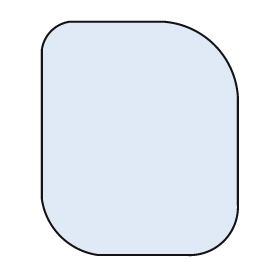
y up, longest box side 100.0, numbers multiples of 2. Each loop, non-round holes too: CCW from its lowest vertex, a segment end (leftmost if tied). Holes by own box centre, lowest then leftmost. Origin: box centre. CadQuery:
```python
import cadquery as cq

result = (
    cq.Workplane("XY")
    .moveTo(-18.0, -50.0)
    .lineTo(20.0, -50.0)
    .threePointArc((36.0, -44.0), (42.0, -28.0))
    .lineTo(42.0, 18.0)
    .threePointArc((32.0, 40.0), (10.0, 50.0))
    .lineTo(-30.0, 50.0)
    .threePointArc((-38.0, 46.0), (-42.0, 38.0))
    .lineTo(-42.0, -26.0)
    .threePointArc((-34.0, -42.0), (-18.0, -50.0))
    .close()
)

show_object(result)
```